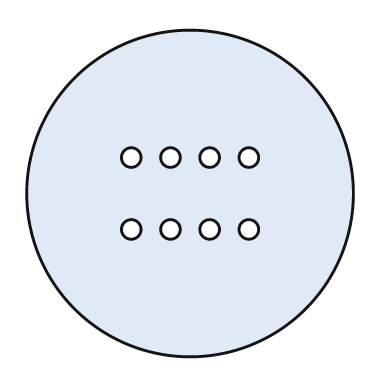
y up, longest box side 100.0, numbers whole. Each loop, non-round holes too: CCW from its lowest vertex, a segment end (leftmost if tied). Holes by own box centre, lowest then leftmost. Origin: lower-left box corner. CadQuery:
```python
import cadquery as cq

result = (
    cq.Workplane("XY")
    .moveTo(50.0, 50.0)
    .circle(50.0)
    .moveTo(32.0, 39.0)
    .circle(3.0)
    .moveTo(44.0, 39.0)
    .circle(3.0)
    .moveTo(56.0, 39.0)
    .circle(3.0)
    .moveTo(68.0, 39.0)
    .circle(3.0)
    .moveTo(32.0, 61.0)
    .circle(3.0)
    .moveTo(44.0, 61.0)
    .circle(3.0)
    .moveTo(56.0, 61.0)
    .circle(3.0)
    .moveTo(68.0, 61.0)
    .circle(3.0)
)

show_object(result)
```